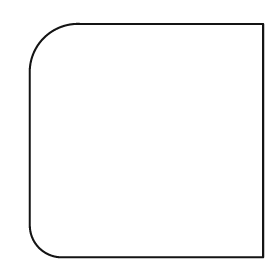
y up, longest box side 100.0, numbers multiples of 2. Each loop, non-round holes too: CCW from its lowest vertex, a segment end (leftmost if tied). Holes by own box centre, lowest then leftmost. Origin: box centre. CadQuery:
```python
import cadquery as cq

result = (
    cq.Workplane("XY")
    .moveTo(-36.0, -50.0)
    .lineTo(50.0, -50.0)
    .lineTo(50.0, 50.0)
    .lineTo(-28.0, 50.0)
    .threePointArc((-44.0, 44.0), (-50.0, 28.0))
    .lineTo(-50.0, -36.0)
    .threePointArc((-46.0, -46.0), (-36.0, -50.0))
    .close()
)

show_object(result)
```